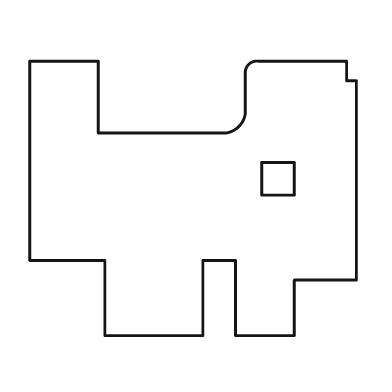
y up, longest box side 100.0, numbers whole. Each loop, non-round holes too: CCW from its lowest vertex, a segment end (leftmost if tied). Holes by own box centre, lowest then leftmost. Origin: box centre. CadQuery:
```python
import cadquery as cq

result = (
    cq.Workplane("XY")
    .moveTo(-27.0, -42.0)
    .lineTo(3.0, -42.0)
    .lineTo(3.0, -19.0)
    .lineTo(13.0, -19.0)
    .lineTo(13.0, -42.0)
    .lineTo(31.0, -42.0)
    .lineTo(31.0, -25.0)
    .lineTo(50.0, -25.0)
    .lineTo(50.0, 36.0)
    .lineTo(47.0, 36.0)
    .lineTo(47.0, 42.0)
    .lineTo(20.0, 42.0)
    .threePointArc((17.0, 41.0), (16.0, 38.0))
    .lineTo(16.0, 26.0)
    .threePointArc((14.0, 22.0), (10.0, 20.0))
    .lineTo(-29.0, 20.0)
    .lineTo(-29.0, 42.0)
    .lineTo(-50.0, 42.0)
    .lineTo(-50.0, -19.0)
    .lineTo(-27.0, -19.0)
    .close()
    .moveTo(21.0, 1.0)
    .lineTo(31.0, 1.0)
    .lineTo(31.0, 11.0)
    .lineTo(21.0, 11.0)
    .close()
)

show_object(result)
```